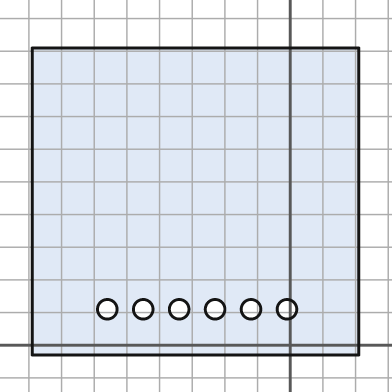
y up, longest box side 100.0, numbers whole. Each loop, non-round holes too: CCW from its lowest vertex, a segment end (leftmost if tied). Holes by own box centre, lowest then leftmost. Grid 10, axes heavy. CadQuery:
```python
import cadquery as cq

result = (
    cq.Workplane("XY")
    .moveTo(-79.0, -3.0)
    .lineTo(21.0, -3.0)
    .lineTo(21.0, 91.0)
    .lineTo(-79.0, 91.0)
    .close()
    .moveTo(-56.0, 11.0)
    .circle(3.0)
    .moveTo(-45.0, 11.0)
    .circle(3.0)
    .moveTo(-34.0, 11.0)
    .circle(3.0)
    .moveTo(-23.0, 11.0)
    .circle(3.0)
    .moveTo(-12.0, 11.0)
    .circle(3.0)
    .moveTo(-1.0, 11.0)
    .circle(3.0)
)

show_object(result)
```